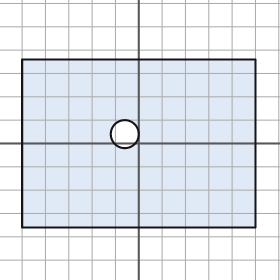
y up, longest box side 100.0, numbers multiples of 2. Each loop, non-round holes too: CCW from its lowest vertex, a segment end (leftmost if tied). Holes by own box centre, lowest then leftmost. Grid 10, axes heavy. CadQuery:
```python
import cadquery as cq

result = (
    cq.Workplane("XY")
    .moveTo(-50.0, -36.0)
    .lineTo(50.0, -36.0)
    .lineTo(50.0, 36.0)
    .lineTo(-50.0, 36.0)
    .close()
    .moveTo(-6.0, 4.0)
    .circle(6.0)
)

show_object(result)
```